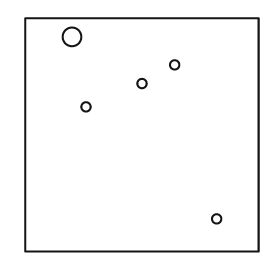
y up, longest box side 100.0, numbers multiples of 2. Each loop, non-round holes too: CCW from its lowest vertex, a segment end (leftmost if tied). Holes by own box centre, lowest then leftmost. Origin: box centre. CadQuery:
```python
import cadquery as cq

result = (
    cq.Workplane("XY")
    .moveTo(-50.0, -50.0)
    .lineTo(50.0, -50.0)
    .lineTo(50.0, 50.0)
    .lineTo(-50.0, 50.0)
    .close()
    .moveTo(32.0, -36.0)
    .circle(2.0)
    .moveTo(-24.0, 12.0)
    .circle(2.0)
    .moveTo(0.0, 22.0)
    .circle(2.0)
    .moveTo(14.0, 30.0)
    .circle(2.0)
    .moveTo(-30.0, 42.0)
    .circle(4.0)
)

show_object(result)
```